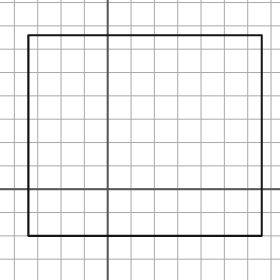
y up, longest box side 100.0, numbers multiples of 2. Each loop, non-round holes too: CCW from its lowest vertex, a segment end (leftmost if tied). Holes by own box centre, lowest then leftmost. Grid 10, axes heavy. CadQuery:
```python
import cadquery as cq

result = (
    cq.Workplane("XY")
    .moveTo(-34.0, -20.0)
    .lineTo(66.0, -20.0)
    .lineTo(66.0, 66.0)
    .lineTo(-34.0, 66.0)
    .close()
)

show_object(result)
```